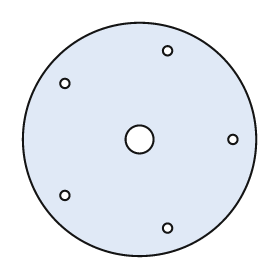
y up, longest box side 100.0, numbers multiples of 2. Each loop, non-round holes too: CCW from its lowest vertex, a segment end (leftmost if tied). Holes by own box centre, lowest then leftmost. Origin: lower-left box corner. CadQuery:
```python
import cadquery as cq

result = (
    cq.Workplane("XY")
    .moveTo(50.0, 50.0)
    .circle(50.0)
    .moveTo(62.0, 12.0)
    .circle(2.0)
    .moveTo(18.0, 26.0)
    .circle(2.0)
    .moveTo(50.0, 50.0)
    .circle(6.0)
    .moveTo(90.0, 50.0)
    .circle(2.0)
    .moveTo(18.0, 74.0)
    .circle(2.0)
    .moveTo(62.0, 88.0)
    .circle(2.0)
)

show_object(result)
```